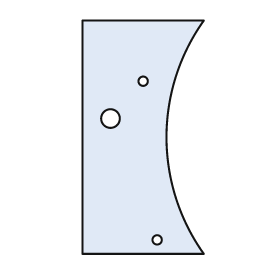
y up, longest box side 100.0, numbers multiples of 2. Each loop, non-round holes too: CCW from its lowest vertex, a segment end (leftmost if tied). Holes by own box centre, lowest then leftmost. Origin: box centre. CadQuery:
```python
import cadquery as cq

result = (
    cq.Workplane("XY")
    .moveTo(-26.0, -50.0)
    .lineTo(26.0, -50.0)
    .threePointArc((10.0, 0.0), (26.0, 50.0))
    .lineTo(-26.0, 50.0)
    .close()
    .moveTo(6.0, -44.0)
    .circle(2.0)
    .moveTo(-14.0, 8.0)
    .circle(4.0)
    .moveTo(0.0, 24.0)
    .circle(2.0)
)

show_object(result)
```